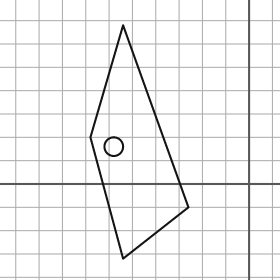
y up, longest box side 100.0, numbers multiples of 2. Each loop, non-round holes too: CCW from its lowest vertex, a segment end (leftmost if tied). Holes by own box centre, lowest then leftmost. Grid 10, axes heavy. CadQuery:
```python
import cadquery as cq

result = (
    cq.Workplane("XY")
    .moveTo(-54.0, -32.0)
    .lineTo(-26.0, -10.0)
    .lineTo(-54.0, 68.0)
    .lineTo(-68.0, 20.0)
    .close()
    .moveTo(-58.0, 16.0)
    .circle(4.0)
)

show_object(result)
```